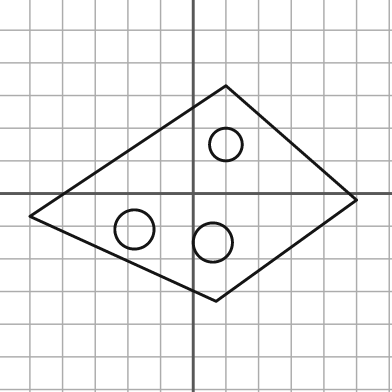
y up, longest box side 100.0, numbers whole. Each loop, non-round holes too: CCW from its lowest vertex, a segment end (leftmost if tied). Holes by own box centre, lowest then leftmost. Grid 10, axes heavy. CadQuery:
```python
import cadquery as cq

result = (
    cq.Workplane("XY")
    .moveTo(7.0, -33.0)
    .lineTo(50.0, -2.0)
    .lineTo(10.0, 33.0)
    .lineTo(-50.0, -7.0)
    .close()
    .moveTo(6.0, -15.0)
    .circle(6.0)
    .moveTo(-18.0, -11.0)
    .circle(6.0)
    .moveTo(10.0, 15.0)
    .circle(5.0)
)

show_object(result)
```